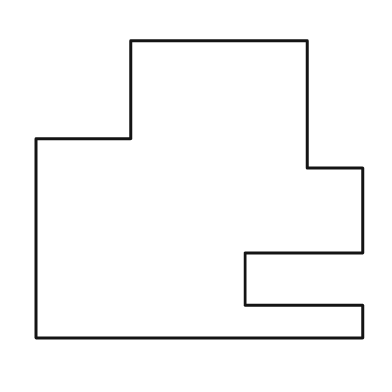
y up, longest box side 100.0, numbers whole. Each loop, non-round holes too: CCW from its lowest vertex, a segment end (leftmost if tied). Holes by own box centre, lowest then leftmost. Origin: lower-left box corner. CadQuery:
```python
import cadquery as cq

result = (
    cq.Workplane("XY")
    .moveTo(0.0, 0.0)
    .lineTo(100.0, 0.0)
    .lineTo(100.0, 10.0)
    .lineTo(64.0, 10.0)
    .lineTo(64.0, 26.0)
    .lineTo(100.0, 26.0)
    .lineTo(100.0, 52.0)
    .lineTo(83.0, 52.0)
    .lineTo(83.0, 91.0)
    .lineTo(29.0, 91.0)
    .lineTo(29.0, 61.0)
    .lineTo(0.0, 61.0)
    .close()
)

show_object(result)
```